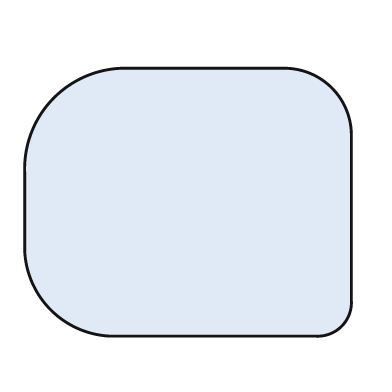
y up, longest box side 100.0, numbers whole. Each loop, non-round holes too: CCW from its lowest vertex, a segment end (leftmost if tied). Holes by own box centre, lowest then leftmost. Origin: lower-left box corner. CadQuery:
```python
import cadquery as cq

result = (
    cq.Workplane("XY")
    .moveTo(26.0, 0.0)
    .lineTo(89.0, 0.0)
    .threePointArc((97.0, 3.0), (100.0, 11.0))
    .lineTo(100.0, 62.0)
    .threePointArc((94.0, 76.0), (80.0, 82.0))
    .lineTo(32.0, 82.0)
    .threePointArc((9.0, 73.0), (0.0, 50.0))
    .lineTo(0.0, 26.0)
    .threePointArc((8.0, 8.0), (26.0, 0.0))
    .close()
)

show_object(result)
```